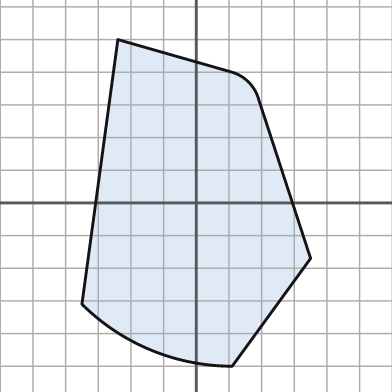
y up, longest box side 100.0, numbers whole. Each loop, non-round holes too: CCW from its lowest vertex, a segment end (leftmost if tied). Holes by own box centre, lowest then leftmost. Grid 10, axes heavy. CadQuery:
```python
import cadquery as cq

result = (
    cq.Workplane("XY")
    .moveTo(11.0, -50.0)
    .lineTo(35.0, -17.0)
    .lineTo(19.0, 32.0)
    .threePointArc((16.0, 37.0), (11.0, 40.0))
    .lineTo(-24.0, 50.0)
    .lineTo(-35.0, -31.0)
    .threePointArc((-14.0, -45.0), (11.0, -50.0))
    .close()
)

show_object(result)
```